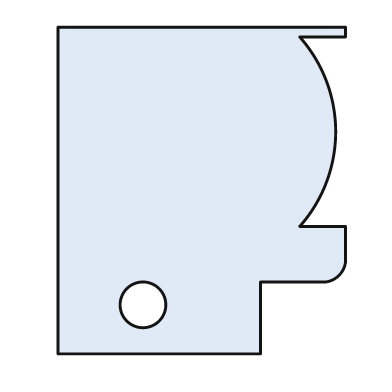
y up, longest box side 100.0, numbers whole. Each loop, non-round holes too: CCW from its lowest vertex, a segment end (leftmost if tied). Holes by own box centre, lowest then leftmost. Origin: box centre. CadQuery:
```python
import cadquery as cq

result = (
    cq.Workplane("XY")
    .moveTo(-44.0, -50.0)
    .lineTo(18.0, -50.0)
    .lineTo(18.0, -28.0)
    .lineTo(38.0, -28.0)
    .threePointArc((42.0, -26.0), (44.0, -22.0))
    .lineTo(44.0, -11.0)
    .lineTo(30.0, -11.0)
    .threePointArc((41.0, 18.0), (30.0, 47.0))
    .lineTo(44.0, 47.0)
    .lineTo(44.0, 50.0)
    .lineTo(-44.0, 50.0)
    .close()
    .moveTo(-18.0, -35.0)
    .circle(7.0)
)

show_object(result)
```